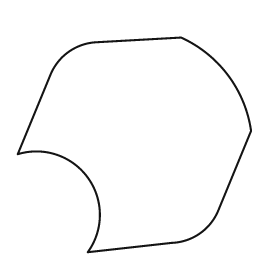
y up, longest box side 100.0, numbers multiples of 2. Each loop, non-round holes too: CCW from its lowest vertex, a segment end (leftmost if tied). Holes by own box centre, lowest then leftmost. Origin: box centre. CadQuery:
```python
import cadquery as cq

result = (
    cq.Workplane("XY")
    .moveTo(-20.0, -46.0)
    .lineTo(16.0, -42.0)
    .threePointArc((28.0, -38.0), (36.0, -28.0))
    .lineTo(50.0, 6.0)
    .threePointArc((40.0, 30.0), (20.0, 46.0))
    .lineTo(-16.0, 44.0)
    .threePointArc((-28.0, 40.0), (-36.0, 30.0))
    .lineTo(-50.0, -4.0)
    .threePointArc((-20.0, -14.0), (-20.0, -46.0))
    .close()
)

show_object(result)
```